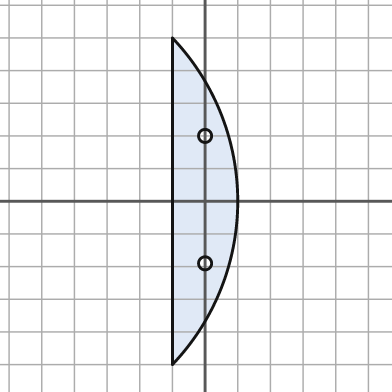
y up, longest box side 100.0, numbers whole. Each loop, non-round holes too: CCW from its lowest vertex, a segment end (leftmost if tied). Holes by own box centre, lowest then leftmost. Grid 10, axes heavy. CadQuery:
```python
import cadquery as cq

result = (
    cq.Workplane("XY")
    .moveTo(-10.0, -50.0)
    .threePointArc((10.0, 0.0), (-10.0, 50.0))
    .close()
    .moveTo(0.0, -19.0)
    .circle(2.0)
    .moveTo(0.0, 20.0)
    .circle(2.0)
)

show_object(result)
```